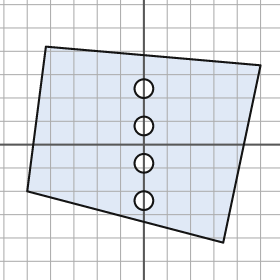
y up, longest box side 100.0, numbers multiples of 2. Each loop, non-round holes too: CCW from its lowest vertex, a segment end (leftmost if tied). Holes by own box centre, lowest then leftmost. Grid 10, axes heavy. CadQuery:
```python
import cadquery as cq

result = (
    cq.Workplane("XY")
    .moveTo(34.0, -42.0)
    .lineTo(50.0, 34.0)
    .lineTo(-42.0, 42.0)
    .lineTo(-50.0, -20.0)
    .close()
    .moveTo(0.0, -24.0)
    .circle(4.0)
    .moveTo(0.0, -8.0)
    .circle(4.0)
    .moveTo(0.0, 8.0)
    .circle(4.0)
    .moveTo(0.0, 24.0)
    .circle(4.0)
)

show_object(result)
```